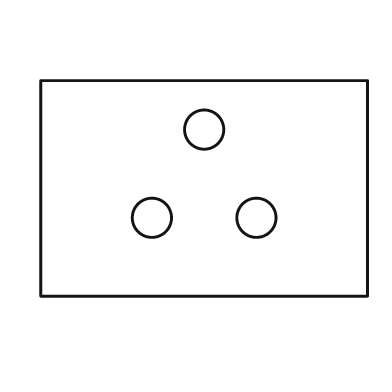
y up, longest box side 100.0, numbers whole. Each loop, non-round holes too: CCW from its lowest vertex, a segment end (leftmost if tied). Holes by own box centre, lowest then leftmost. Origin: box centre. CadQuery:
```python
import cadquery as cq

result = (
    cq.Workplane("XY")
    .moveTo(-50.0, -33.0)
    .lineTo(50.0, -33.0)
    .lineTo(50.0, 33.0)
    .lineTo(-50.0, 33.0)
    .close()
    .moveTo(-16.0, -9.0)
    .circle(6.0)
    .moveTo(16.0, -9.0)
    .circle(6.0)
    .moveTo(0.0, 18.0)
    .circle(6.0)
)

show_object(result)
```